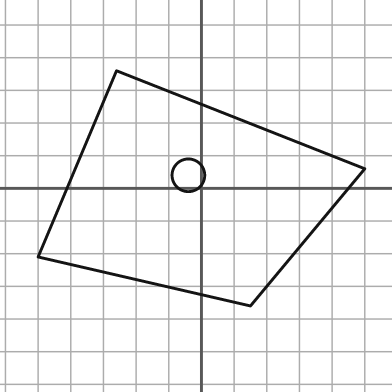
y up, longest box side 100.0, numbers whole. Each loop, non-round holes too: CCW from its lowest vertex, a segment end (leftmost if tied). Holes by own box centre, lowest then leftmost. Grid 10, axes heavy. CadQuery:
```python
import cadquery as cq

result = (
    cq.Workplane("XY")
    .moveTo(15.0, -36.0)
    .lineTo(50.0, 6.0)
    .lineTo(-26.0, 36.0)
    .lineTo(-50.0, -21.0)
    .close()
    .moveTo(-4.0, 4.0)
    .circle(5.0)
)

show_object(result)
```